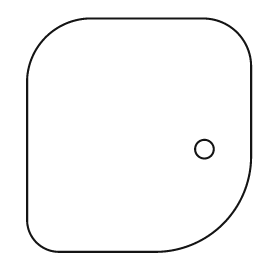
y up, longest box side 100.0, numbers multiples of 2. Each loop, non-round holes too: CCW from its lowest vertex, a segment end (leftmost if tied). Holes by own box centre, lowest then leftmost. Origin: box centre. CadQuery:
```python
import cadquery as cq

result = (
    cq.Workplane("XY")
    .moveTo(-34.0, -50.0)
    .lineTo(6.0, -50.0)
    .threePointArc((36.0, -38.0), (48.0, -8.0))
    .lineTo(48.0, 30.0)
    .threePointArc((42.0, 44.0), (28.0, 50.0))
    .lineTo(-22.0, 50.0)
    .threePointArc((-40.0, 42.0), (-48.0, 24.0))
    .lineTo(-48.0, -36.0)
    .threePointArc((-44.0, -46.0), (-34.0, -50.0))
    .close()
    .moveTo(28.0, -6.0)
    .circle(4.0)
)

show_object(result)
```